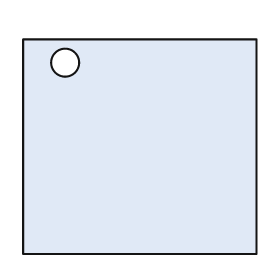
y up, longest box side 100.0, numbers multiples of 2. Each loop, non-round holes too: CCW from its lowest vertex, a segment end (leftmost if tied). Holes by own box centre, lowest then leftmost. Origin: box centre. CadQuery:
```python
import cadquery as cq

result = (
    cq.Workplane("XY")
    .moveTo(-50.0, -46.0)
    .lineTo(50.0, -46.0)
    .lineTo(50.0, 46.0)
    .lineTo(-50.0, 46.0)
    .close()
    .moveTo(-32.0, 36.0)
    .circle(6.0)
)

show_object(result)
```